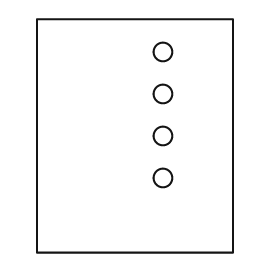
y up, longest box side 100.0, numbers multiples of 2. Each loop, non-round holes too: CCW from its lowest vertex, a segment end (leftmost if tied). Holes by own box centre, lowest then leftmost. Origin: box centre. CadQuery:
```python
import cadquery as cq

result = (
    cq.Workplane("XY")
    .moveTo(-42.0, -50.0)
    .lineTo(42.0, -50.0)
    .lineTo(42.0, 50.0)
    .lineTo(-42.0, 50.0)
    .close()
    .moveTo(12.0, -18.0)
    .circle(4.0)
    .moveTo(12.0, 0.0)
    .circle(4.0)
    .moveTo(12.0, 18.0)
    .circle(4.0)
    .moveTo(12.0, 36.0)
    .circle(4.0)
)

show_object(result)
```